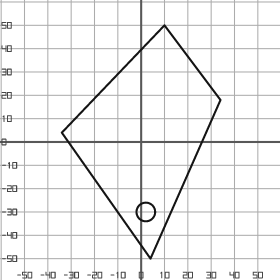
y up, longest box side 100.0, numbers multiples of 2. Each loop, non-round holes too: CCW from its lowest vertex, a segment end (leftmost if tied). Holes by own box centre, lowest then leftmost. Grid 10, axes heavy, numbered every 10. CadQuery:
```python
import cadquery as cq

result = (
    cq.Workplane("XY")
    .moveTo(4.0, -50.0)
    .lineTo(34.0, 18.0)
    .lineTo(10.0, 50.0)
    .lineTo(-34.0, 4.0)
    .close()
    .moveTo(2.0, -30.0)
    .circle(4.0)
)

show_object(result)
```